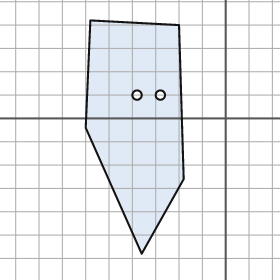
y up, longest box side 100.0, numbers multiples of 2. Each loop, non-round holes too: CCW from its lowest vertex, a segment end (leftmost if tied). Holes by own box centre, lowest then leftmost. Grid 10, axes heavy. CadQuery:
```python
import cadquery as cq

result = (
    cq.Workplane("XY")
    .moveTo(-36.0, -58.0)
    .lineTo(-18.0, -26.0)
    .lineTo(-20.0, 40.0)
    .lineTo(-58.0, 42.0)
    .lineTo(-60.0, -4.0)
    .close()
    .moveTo(-38.0, 10.0)
    .circle(2.0)
    .moveTo(-28.0, 10.0)
    .circle(2.0)
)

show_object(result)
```